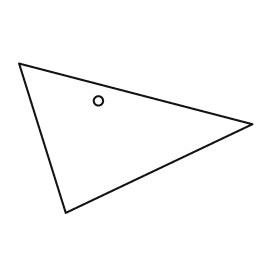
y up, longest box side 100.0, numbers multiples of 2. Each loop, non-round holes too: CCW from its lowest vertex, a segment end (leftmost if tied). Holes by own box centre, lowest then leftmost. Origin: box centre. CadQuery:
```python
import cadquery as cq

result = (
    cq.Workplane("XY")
    .moveTo(-30.0, -32.0)
    .lineTo(50.0, 6.0)
    .lineTo(-50.0, 32.0)
    .close()
    .moveTo(-16.0, 16.0)
    .circle(2.0)
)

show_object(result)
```